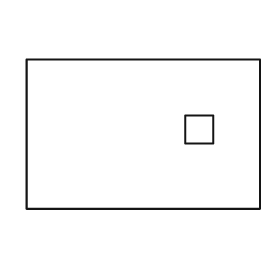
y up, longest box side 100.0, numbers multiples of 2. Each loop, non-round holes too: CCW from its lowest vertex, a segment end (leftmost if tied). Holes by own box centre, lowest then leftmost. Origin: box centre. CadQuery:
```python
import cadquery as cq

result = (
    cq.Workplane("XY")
    .moveTo(-50.0, -32.0)
    .lineTo(50.0, -32.0)
    .lineTo(50.0, 32.0)
    .lineTo(-50.0, 32.0)
    .close()
    .moveTo(18.0, -4.0)
    .lineTo(30.0, -4.0)
    .lineTo(30.0, 8.0)
    .lineTo(18.0, 8.0)
    .close()
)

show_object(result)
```